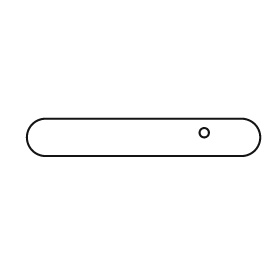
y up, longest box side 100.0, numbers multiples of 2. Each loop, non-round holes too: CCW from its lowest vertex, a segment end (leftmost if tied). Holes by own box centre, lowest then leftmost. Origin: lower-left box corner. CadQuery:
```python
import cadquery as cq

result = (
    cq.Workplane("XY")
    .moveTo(8.0, 0.0)
    .lineTo(92.0, 0.0)
    .threePointArc((100.0, 8.0), (92.0, 16.0))
    .lineTo(8.0, 16.0)
    .threePointArc((0.0, 8.0), (8.0, 0.0))
    .close()
    .moveTo(76.0, 10.0)
    .circle(2.0)
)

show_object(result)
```